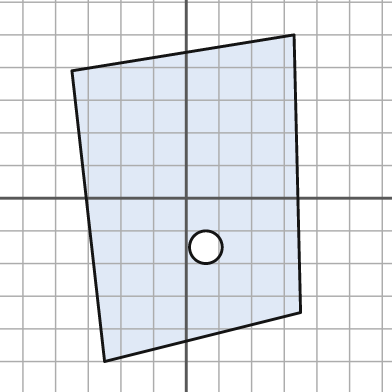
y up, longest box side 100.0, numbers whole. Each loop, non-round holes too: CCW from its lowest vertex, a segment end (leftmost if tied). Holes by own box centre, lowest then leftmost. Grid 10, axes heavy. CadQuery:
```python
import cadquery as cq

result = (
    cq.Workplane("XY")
    .moveTo(-25.0, -50.0)
    .lineTo(35.0, -35.0)
    .lineTo(33.0, 50.0)
    .lineTo(-35.0, 39.0)
    .close()
    .moveTo(6.0, -15.0)
    .circle(5.0)
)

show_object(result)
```